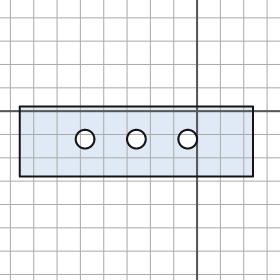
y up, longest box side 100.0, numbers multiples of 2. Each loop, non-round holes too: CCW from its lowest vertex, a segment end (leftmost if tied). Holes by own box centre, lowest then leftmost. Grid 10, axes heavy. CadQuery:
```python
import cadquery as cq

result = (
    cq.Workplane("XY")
    .moveTo(-76.0, -28.0)
    .lineTo(24.0, -28.0)
    .lineTo(24.0, 2.0)
    .lineTo(-76.0, 2.0)
    .close()
    .moveTo(-48.0, -12.0)
    .circle(4.0)
    .moveTo(-26.0, -12.0)
    .circle(4.0)
    .moveTo(-4.0, -12.0)
    .circle(4.0)
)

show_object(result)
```